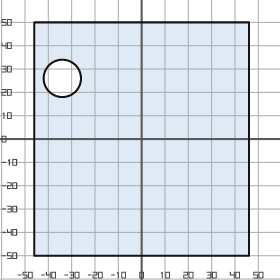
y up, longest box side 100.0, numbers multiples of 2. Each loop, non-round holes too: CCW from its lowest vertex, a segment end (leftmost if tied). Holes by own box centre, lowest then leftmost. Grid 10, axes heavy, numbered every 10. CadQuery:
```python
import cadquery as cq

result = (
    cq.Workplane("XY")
    .moveTo(-46.0, -50.0)
    .lineTo(46.0, -50.0)
    .lineTo(46.0, 50.0)
    .lineTo(-46.0, 50.0)
    .close()
    .moveTo(-34.0, 26.0)
    .circle(8.0)
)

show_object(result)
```